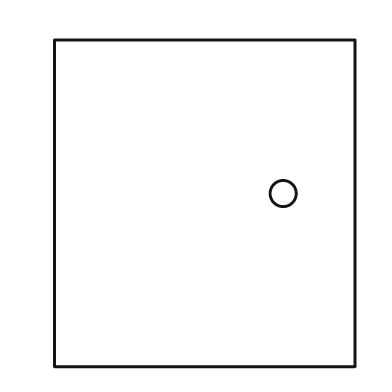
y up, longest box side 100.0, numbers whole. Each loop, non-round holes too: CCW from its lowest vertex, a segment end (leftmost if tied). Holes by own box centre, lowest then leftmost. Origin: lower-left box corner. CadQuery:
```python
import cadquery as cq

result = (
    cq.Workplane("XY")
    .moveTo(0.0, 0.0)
    .lineTo(92.0, 0.0)
    .lineTo(92.0, 100.0)
    .lineTo(0.0, 100.0)
    .close()
    .moveTo(70.0, 53.0)
    .circle(4.0)
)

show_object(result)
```